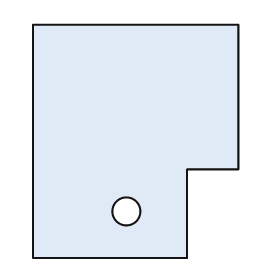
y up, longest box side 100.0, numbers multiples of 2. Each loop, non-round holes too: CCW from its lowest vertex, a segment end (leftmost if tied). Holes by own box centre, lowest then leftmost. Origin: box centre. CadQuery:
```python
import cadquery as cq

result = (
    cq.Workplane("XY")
    .moveTo(-44.0, -50.0)
    .lineTo(22.0, -50.0)
    .lineTo(22.0, -12.0)
    .lineTo(44.0, -12.0)
    .lineTo(44.0, 50.0)
    .lineTo(-44.0, 50.0)
    .close()
    .moveTo(-4.0, -30.0)
    .circle(6.0)
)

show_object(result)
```